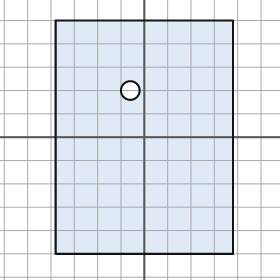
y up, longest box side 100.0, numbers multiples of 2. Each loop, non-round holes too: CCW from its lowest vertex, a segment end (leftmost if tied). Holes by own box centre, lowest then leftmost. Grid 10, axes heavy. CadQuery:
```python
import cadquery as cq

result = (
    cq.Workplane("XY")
    .moveTo(-38.0, -50.0)
    .lineTo(38.0, -50.0)
    .lineTo(38.0, 50.0)
    .lineTo(-38.0, 50.0)
    .close()
    .moveTo(-6.0, 20.0)
    .circle(4.0)
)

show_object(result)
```